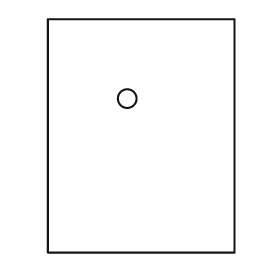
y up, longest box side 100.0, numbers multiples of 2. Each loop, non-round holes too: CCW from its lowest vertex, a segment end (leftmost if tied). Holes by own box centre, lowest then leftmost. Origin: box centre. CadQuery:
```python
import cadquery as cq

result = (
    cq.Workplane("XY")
    .moveTo(-40.0, -50.0)
    .lineTo(40.0, -50.0)
    .lineTo(40.0, 50.0)
    .lineTo(-40.0, 50.0)
    .close()
    .moveTo(-6.0, 16.0)
    .circle(4.0)
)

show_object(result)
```